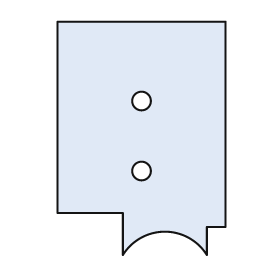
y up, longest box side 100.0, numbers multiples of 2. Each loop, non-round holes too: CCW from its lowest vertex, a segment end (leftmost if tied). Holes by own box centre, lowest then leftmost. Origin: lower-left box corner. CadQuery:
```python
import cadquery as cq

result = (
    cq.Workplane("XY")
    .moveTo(28.0, 0.0)
    .threePointArc((46.0, 10.0), (64.0, 0.0))
    .lineTo(64.0, 12.0)
    .lineTo(72.0, 12.0)
    .lineTo(72.0, 100.0)
    .lineTo(0.0, 100.0)
    .lineTo(0.0, 18.0)
    .lineTo(28.0, 18.0)
    .close()
    .moveTo(36.0, 36.0)
    .circle(4.0)
    .moveTo(36.0, 66.0)
    .circle(4.0)
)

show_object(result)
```